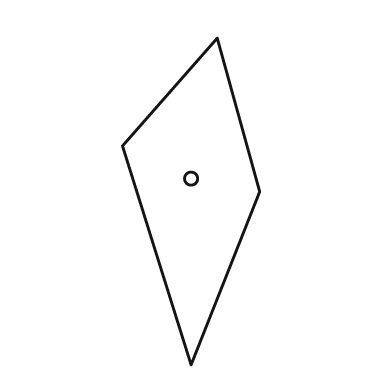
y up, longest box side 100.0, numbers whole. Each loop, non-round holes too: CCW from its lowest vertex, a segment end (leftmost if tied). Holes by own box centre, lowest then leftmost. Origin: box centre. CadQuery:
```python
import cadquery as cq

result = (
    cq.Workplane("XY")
    .moveTo(0.0, -50.0)
    .lineTo(21.0, 3.0)
    .lineTo(8.0, 50.0)
    .lineTo(-21.0, 17.0)
    .close()
    .moveTo(0.0, 7.0)
    .circle(2.0)
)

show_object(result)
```